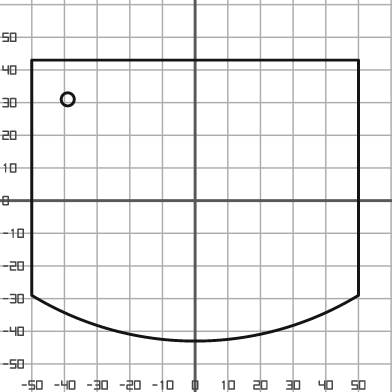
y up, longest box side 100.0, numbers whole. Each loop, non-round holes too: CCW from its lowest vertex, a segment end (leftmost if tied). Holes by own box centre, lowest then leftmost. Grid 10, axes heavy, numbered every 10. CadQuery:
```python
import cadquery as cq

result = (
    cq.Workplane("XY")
    .moveTo(-50.0, -29.0)
    .threePointArc((0.0, -43.0), (50.0, -29.0))
    .lineTo(50.0, 43.0)
    .lineTo(-50.0, 43.0)
    .close()
    .moveTo(-39.0, 31.0)
    .circle(2.0)
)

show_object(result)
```